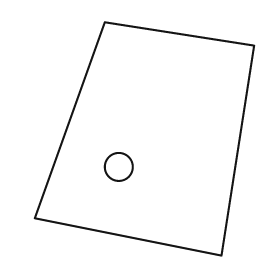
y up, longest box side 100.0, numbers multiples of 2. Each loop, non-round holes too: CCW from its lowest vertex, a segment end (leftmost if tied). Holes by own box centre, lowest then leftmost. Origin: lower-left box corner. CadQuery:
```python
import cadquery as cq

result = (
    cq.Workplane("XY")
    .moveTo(80.0, 0.0)
    .lineTo(94.0, 90.0)
    .lineTo(30.0, 100.0)
    .lineTo(0.0, 16.0)
    .close()
    .moveTo(36.0, 38.0)
    .circle(6.0)
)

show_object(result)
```